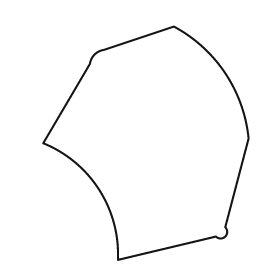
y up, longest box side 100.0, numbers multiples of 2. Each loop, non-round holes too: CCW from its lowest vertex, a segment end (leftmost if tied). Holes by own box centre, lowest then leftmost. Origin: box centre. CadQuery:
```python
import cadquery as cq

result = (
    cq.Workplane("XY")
    .moveTo(-12.0, -50.0)
    .lineTo(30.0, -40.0)
    .threePointArc((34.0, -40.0), (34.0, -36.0))
    .lineTo(44.0, 2.0)
    .threePointArc((34.0, 30.0), (12.0, 50.0))
    .lineTo(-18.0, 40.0)
    .threePointArc((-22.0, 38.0), (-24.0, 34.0))
    .lineTo(-44.0, 0.0)
    .threePointArc((-20.0, -20.0), (-12.0, -50.0))
    .close()
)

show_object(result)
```